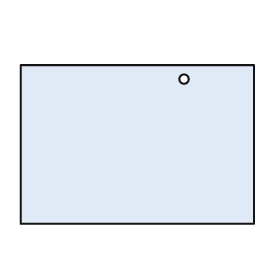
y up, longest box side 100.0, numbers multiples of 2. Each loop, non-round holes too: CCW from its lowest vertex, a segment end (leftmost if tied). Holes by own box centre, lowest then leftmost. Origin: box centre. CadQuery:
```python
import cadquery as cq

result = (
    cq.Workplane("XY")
    .moveTo(-50.0, -34.0)
    .lineTo(50.0, -34.0)
    .lineTo(50.0, 34.0)
    .lineTo(-50.0, 34.0)
    .close()
    .moveTo(20.0, 28.0)
    .circle(2.0)
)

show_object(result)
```